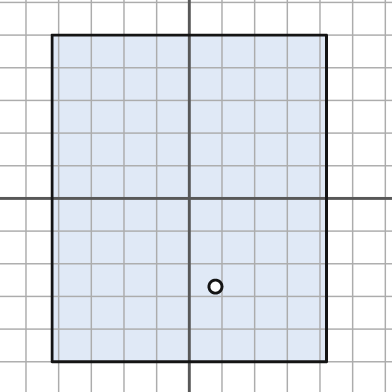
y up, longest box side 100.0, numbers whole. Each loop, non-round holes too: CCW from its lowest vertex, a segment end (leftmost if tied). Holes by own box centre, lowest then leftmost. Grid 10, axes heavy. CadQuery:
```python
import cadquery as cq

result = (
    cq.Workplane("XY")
    .moveTo(-42.0, -50.0)
    .lineTo(42.0, -50.0)
    .lineTo(42.0, 50.0)
    .lineTo(-42.0, 50.0)
    .close()
    .moveTo(8.0, -27.0)
    .circle(2.0)
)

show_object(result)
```